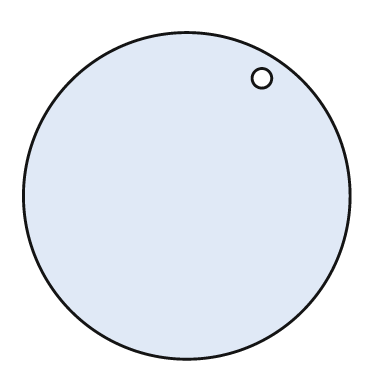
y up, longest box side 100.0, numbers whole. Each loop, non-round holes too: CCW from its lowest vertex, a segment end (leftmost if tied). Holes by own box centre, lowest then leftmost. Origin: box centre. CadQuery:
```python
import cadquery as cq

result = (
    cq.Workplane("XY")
    .moveTo(0.0, 0.0)
    .circle(50.0)
    .moveTo(23.0, 36.0)
    .circle(3.0)
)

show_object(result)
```